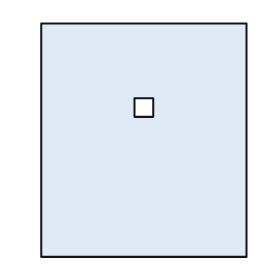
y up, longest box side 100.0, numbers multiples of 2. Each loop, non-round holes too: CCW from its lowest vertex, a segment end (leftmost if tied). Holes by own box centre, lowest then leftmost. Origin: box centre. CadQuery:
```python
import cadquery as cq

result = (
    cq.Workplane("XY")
    .moveTo(-44.0, -50.0)
    .lineTo(44.0, -50.0)
    .lineTo(44.0, 50.0)
    .lineTo(-44.0, 50.0)
    .close()
    .moveTo(-4.0, 10.0)
    .lineTo(4.0, 10.0)
    .lineTo(4.0, 18.0)
    .lineTo(-4.0, 18.0)
    .close()
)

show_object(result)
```